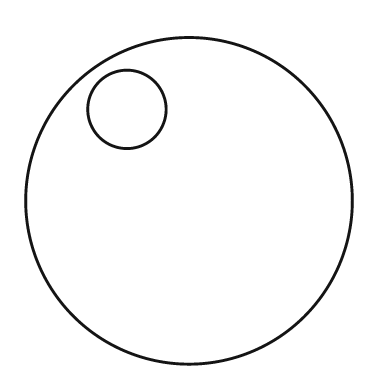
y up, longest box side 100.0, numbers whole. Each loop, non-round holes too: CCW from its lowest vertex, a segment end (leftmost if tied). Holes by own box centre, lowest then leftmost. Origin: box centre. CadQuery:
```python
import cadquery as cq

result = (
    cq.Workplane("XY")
    .moveTo(0.0, 0.0)
    .circle(50.0)
    .moveTo(-19.0, 28.0)
    .circle(12.0)
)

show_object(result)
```